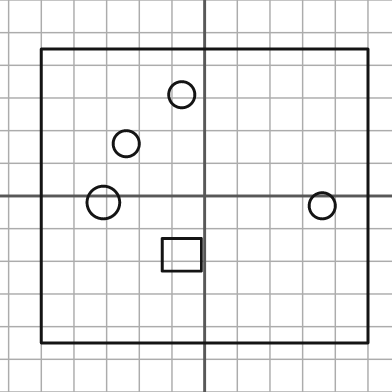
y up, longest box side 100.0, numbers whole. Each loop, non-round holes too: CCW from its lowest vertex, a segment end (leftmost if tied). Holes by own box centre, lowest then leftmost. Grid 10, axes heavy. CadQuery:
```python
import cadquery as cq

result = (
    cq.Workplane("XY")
    .moveTo(-50.0, -45.0)
    .lineTo(50.0, -45.0)
    .lineTo(50.0, 45.0)
    .lineTo(-50.0, 45.0)
    .close()
    .moveTo(-13.0, -23.0)
    .lineTo(-1.0, -23.0)
    .lineTo(-1.0, -13.0)
    .lineTo(-13.0, -13.0)
    .close()
    .moveTo(36.0, -3.0)
    .circle(4.0)
    .moveTo(-31.0, -2.0)
    .circle(5.0)
    .moveTo(-24.0, 16.0)
    .circle(4.0)
    .moveTo(-7.0, 31.0)
    .circle(4.0)
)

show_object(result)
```